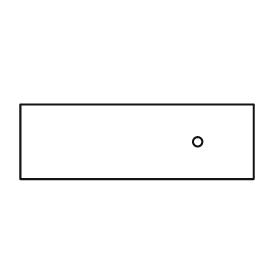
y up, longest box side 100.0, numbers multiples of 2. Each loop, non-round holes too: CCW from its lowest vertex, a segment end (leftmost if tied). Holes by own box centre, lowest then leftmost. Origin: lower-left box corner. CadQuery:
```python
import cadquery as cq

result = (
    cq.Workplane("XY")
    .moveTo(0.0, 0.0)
    .lineTo(100.0, 0.0)
    .lineTo(100.0, 32.0)
    .lineTo(0.0, 32.0)
    .close()
    .moveTo(76.0, 16.0)
    .circle(2.0)
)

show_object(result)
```